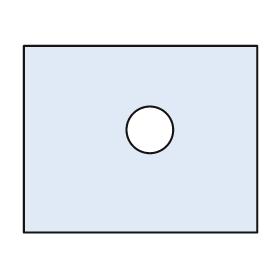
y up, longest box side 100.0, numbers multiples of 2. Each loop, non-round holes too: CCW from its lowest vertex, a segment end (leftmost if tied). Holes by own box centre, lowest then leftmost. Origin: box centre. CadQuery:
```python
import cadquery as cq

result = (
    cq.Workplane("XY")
    .moveTo(-50.0, -40.0)
    .lineTo(50.0, -40.0)
    .lineTo(50.0, 40.0)
    .lineTo(-50.0, 40.0)
    .close()
    .moveTo(4.0, 4.0)
    .circle(10.0)
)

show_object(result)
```